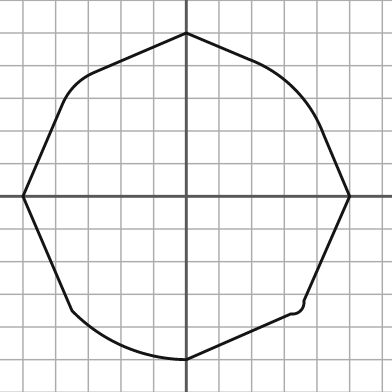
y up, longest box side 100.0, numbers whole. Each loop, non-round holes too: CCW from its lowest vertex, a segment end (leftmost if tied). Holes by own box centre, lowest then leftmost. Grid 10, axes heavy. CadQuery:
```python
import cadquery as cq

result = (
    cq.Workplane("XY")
    .moveTo(0.0, -50.0)
    .lineTo(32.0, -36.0)
    .threePointArc((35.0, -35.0), (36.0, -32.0))
    .lineTo(50.0, 0.0)
    .lineTo(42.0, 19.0)
    .threePointArc((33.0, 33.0), (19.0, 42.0))
    .lineTo(0.0, 50.0)
    .lineTo(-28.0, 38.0)
    .threePointArc((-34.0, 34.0), (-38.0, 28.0))
    .lineTo(-50.0, 0.0)
    .lineTo(-35.0, -35.0)
    .threePointArc((-19.0, -46.0), (0.0, -50.0))
    .close()
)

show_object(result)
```